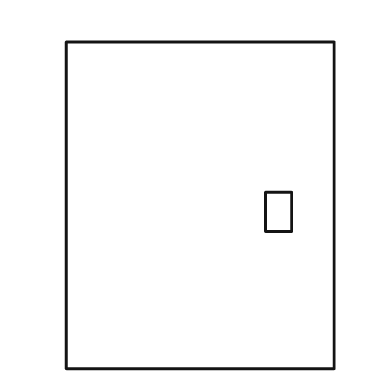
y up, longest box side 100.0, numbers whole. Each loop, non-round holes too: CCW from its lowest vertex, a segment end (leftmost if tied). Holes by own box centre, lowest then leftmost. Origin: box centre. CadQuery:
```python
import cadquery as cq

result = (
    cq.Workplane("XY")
    .moveTo(-41.0, -50.0)
    .lineTo(41.0, -50.0)
    .lineTo(41.0, 50.0)
    .lineTo(-41.0, 50.0)
    .close()
    .moveTo(20.0, -8.0)
    .lineTo(28.0, -8.0)
    .lineTo(28.0, 4.0)
    .lineTo(20.0, 4.0)
    .close()
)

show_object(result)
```